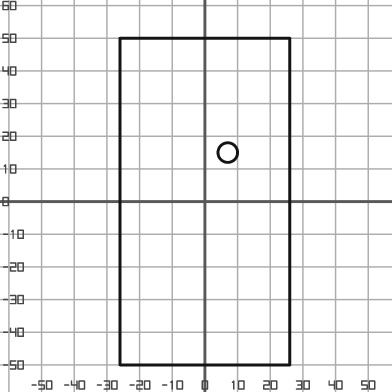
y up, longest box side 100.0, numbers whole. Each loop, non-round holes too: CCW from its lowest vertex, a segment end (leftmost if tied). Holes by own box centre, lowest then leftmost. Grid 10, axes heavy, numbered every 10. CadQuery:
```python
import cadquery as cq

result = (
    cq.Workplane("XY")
    .moveTo(-26.0, -50.0)
    .lineTo(26.0, -50.0)
    .lineTo(26.0, 50.0)
    .lineTo(-26.0, 50.0)
    .close()
    .moveTo(7.0, 15.0)
    .circle(3.0)
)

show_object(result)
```